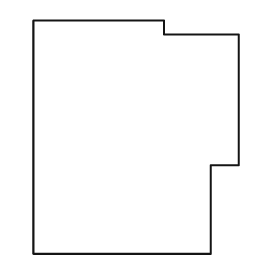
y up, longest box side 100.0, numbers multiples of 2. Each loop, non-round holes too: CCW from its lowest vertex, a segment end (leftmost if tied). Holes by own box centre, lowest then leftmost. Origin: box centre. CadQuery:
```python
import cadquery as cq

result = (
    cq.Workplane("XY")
    .moveTo(-44.0, -50.0)
    .lineTo(32.0, -50.0)
    .lineTo(32.0, -12.0)
    .lineTo(44.0, -12.0)
    .lineTo(44.0, 44.0)
    .lineTo(12.0, 44.0)
    .lineTo(12.0, 50.0)
    .lineTo(-44.0, 50.0)
    .close()
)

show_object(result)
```